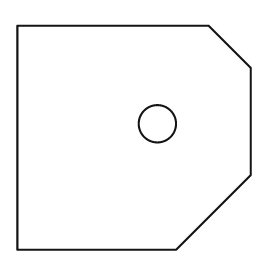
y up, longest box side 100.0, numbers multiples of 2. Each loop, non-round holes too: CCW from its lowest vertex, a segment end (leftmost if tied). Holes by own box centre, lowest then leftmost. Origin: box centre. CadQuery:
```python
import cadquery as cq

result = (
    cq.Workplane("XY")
    .moveTo(-50.0, -48.0)
    .lineTo(18.0, -48.0)
    .lineTo(50.0, -16.0)
    .lineTo(50.0, 30.0)
    .lineTo(32.0, 48.0)
    .lineTo(-50.0, 48.0)
    .close()
    .moveTo(10.0, 6.0)
    .circle(8.0)
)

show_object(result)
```